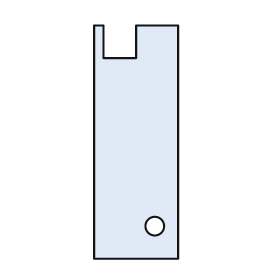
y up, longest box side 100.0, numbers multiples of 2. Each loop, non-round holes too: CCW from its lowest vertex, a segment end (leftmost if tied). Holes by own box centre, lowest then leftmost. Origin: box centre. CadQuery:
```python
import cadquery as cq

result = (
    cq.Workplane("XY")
    .moveTo(-18.0, -50.0)
    .lineTo(18.0, -50.0)
    .lineTo(18.0, 50.0)
    .lineTo(0.0, 50.0)
    .lineTo(0.0, 36.0)
    .lineTo(-14.0, 36.0)
    .lineTo(-14.0, 50.0)
    .lineTo(-18.0, 50.0)
    .close()
    .moveTo(8.0, -36.0)
    .circle(4.0)
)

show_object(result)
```